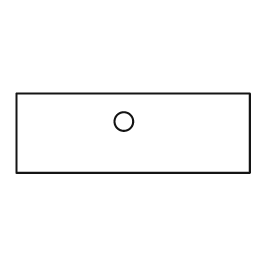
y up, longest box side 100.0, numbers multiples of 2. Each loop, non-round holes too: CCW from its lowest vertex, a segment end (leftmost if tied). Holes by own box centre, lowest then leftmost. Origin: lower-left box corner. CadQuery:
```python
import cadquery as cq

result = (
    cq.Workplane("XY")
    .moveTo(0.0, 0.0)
    .lineTo(100.0, 0.0)
    .lineTo(100.0, 34.0)
    .lineTo(0.0, 34.0)
    .close()
    .moveTo(46.0, 22.0)
    .circle(4.0)
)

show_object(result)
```